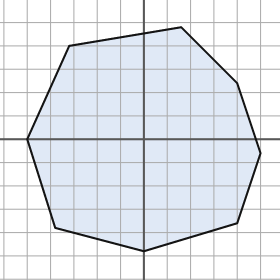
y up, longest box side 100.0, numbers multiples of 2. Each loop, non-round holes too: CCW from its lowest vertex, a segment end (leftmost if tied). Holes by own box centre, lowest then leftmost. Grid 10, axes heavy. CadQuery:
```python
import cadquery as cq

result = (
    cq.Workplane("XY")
    .moveTo(0.0, -48.0)
    .lineTo(40.0, -36.0)
    .lineTo(50.0, -6.0)
    .lineTo(40.0, 24.0)
    .lineTo(16.0, 48.0)
    .lineTo(-32.0, 40.0)
    .lineTo(-50.0, 0.0)
    .lineTo(-38.0, -38.0)
    .close()
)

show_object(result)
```